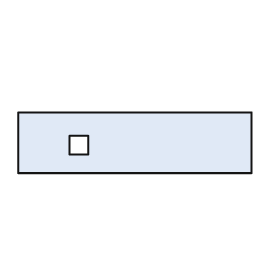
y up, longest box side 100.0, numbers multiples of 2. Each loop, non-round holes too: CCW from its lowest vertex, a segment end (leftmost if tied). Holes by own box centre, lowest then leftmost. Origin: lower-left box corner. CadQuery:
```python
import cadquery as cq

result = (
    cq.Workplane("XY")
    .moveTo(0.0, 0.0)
    .lineTo(100.0, 0.0)
    .lineTo(100.0, 26.0)
    .lineTo(0.0, 26.0)
    .close()
    .moveTo(22.0, 8.0)
    .lineTo(30.0, 8.0)
    .lineTo(30.0, 16.0)
    .lineTo(22.0, 16.0)
    .close()
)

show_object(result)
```